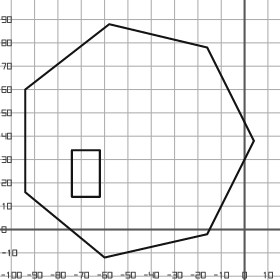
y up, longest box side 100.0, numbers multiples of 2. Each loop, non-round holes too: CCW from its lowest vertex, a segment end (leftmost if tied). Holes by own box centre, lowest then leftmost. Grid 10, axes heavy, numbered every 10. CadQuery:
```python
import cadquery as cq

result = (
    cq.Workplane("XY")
    .moveTo(-60.0, -12.0)
    .lineTo(-16.0, -2.0)
    .lineTo(4.0, 38.0)
    .lineTo(-16.0, 78.0)
    .lineTo(-58.0, 88.0)
    .lineTo(-94.0, 60.0)
    .lineTo(-94.0, 16.0)
    .close()
    .moveTo(-74.0, 14.0)
    .lineTo(-62.0, 14.0)
    .lineTo(-62.0, 34.0)
    .lineTo(-74.0, 34.0)
    .close()
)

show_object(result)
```